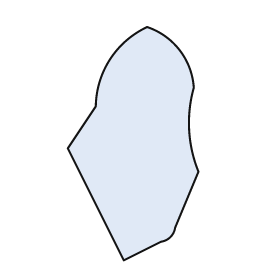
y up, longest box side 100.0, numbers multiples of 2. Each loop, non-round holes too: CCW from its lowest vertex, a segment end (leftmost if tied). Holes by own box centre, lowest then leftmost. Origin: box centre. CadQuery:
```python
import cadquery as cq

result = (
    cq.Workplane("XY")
    .moveTo(-4.0, -50.0)
    .lineTo(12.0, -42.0)
    .threePointArc((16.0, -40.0), (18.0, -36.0))
    .lineTo(28.0, -12.0)
    .threePointArc((24.0, 6.0), (26.0, 24.0))
    .threePointArc((20.0, 40.0), (6.0, 50.0))
    .threePointArc((-10.0, 36.0), (-16.0, 16.0))
    .lineTo(-28.0, -2.0)
    .close()
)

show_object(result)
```